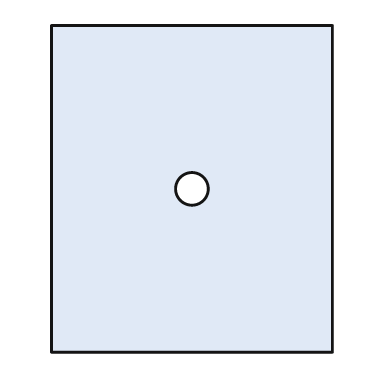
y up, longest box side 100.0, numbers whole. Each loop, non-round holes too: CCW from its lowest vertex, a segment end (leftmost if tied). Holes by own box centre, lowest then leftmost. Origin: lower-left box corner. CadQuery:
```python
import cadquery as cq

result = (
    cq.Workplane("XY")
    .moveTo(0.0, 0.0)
    .lineTo(86.0, 0.0)
    .lineTo(86.0, 100.0)
    .lineTo(0.0, 100.0)
    .close()
    .moveTo(43.0, 50.0)
    .circle(5.0)
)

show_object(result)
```